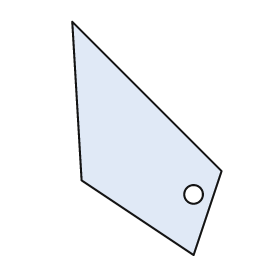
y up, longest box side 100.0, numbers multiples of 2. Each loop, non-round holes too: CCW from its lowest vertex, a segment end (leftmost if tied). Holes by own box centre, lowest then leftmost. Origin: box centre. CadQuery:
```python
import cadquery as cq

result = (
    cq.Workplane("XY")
    .moveTo(20.0, -50.0)
    .lineTo(32.0, -14.0)
    .lineTo(-32.0, 50.0)
    .lineTo(-28.0, -18.0)
    .close()
    .moveTo(20.0, -24.0)
    .circle(4.0)
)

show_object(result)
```